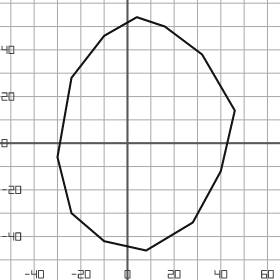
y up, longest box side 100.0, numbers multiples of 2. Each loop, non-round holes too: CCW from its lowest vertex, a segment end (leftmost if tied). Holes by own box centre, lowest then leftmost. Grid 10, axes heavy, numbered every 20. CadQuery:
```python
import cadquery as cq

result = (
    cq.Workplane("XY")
    .moveTo(8.0, -46.0)
    .lineTo(28.0, -34.0)
    .lineTo(40.0, -12.0)
    .lineTo(46.0, 14.0)
    .lineTo(32.0, 38.0)
    .lineTo(16.0, 50.0)
    .lineTo(4.0, 54.0)
    .lineTo(-10.0, 46.0)
    .lineTo(-24.0, 28.0)
    .lineTo(-30.0, -6.0)
    .lineTo(-24.0, -30.0)
    .lineTo(-10.0, -42.0)
    .close()
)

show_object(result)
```